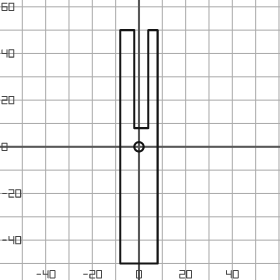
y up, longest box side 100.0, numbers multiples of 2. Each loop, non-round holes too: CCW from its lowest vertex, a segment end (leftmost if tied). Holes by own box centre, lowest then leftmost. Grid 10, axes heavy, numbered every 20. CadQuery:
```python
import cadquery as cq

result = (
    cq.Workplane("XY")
    .moveTo(-8.0, -50.0)
    .lineTo(8.0, -50.0)
    .lineTo(8.0, 50.0)
    .lineTo(4.0, 50.0)
    .lineTo(4.0, 8.0)
    .lineTo(-2.0, 8.0)
    .lineTo(-2.0, 50.0)
    .lineTo(-8.0, 50.0)
    .close()
    .moveTo(0.0, 0.0)
    .circle(2.0)
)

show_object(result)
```